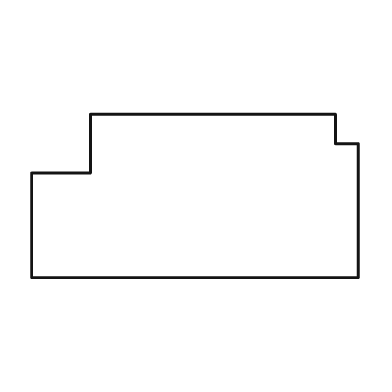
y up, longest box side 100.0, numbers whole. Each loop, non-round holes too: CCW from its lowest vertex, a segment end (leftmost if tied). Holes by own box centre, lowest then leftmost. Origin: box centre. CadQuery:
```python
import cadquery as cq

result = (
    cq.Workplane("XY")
    .moveTo(-50.0, -25.0)
    .lineTo(50.0, -25.0)
    .lineTo(50.0, 16.0)
    .lineTo(43.0, 16.0)
    .lineTo(43.0, 25.0)
    .lineTo(-32.0, 25.0)
    .lineTo(-32.0, 7.0)
    .lineTo(-50.0, 7.0)
    .close()
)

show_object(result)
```